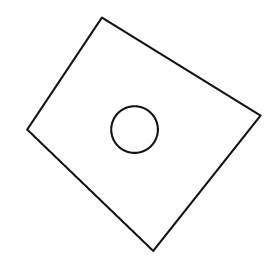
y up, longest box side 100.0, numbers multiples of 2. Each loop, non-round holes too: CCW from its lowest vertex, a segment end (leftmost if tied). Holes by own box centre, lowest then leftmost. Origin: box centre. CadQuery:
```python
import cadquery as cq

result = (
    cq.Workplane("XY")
    .moveTo(4.0, -50.0)
    .lineTo(50.0, 8.0)
    .lineTo(-18.0, 50.0)
    .lineTo(-50.0, 2.0)
    .close()
    .moveTo(-4.0, 2.0)
    .circle(10.0)
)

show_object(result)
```